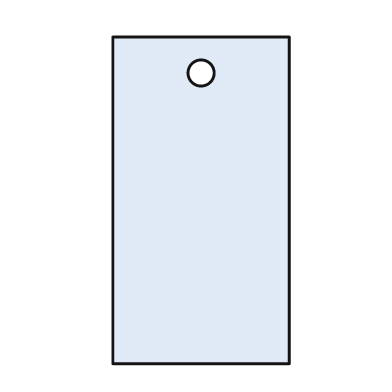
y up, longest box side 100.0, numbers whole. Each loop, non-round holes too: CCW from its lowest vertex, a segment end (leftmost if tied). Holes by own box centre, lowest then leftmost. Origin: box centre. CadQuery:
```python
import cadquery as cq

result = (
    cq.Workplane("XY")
    .moveTo(-27.0, -50.0)
    .lineTo(27.0, -50.0)
    .lineTo(27.0, 50.0)
    .lineTo(-27.0, 50.0)
    .close()
    .moveTo(0.0, 39.0)
    .circle(4.0)
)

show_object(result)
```